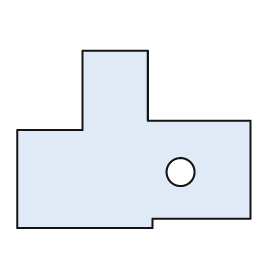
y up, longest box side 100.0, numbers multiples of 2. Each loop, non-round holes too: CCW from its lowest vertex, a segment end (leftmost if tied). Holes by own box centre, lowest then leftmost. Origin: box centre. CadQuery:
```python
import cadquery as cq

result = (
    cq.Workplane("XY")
    .moveTo(-50.0, -38.0)
    .lineTo(8.0, -38.0)
    .lineTo(8.0, -34.0)
    .lineTo(50.0, -34.0)
    .lineTo(50.0, 8.0)
    .lineTo(6.0, 8.0)
    .lineTo(6.0, 38.0)
    .lineTo(-22.0, 38.0)
    .lineTo(-22.0, 4.0)
    .lineTo(-50.0, 4.0)
    .close()
    .moveTo(20.0, -14.0)
    .circle(6.0)
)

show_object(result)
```